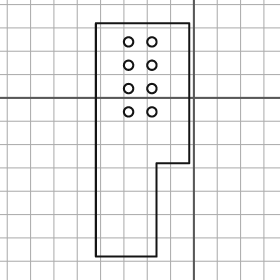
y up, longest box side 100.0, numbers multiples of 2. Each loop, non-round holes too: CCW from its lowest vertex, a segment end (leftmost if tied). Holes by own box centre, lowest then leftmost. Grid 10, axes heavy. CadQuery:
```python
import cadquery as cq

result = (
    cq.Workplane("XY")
    .moveTo(-42.0, -68.0)
    .lineTo(-16.0, -68.0)
    .lineTo(-16.0, -28.0)
    .lineTo(-2.0, -28.0)
    .lineTo(-2.0, 32.0)
    .lineTo(-42.0, 32.0)
    .close()
    .moveTo(-28.0, -6.0)
    .circle(2.0)
    .moveTo(-18.0, -6.0)
    .circle(2.0)
    .moveTo(-28.0, 4.0)
    .circle(2.0)
    .moveTo(-18.0, 4.0)
    .circle(2.0)
    .moveTo(-28.0, 14.0)
    .circle(2.0)
    .moveTo(-18.0, 14.0)
    .circle(2.0)
    .moveTo(-28.0, 24.0)
    .circle(2.0)
    .moveTo(-18.0, 24.0)
    .circle(2.0)
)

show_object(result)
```